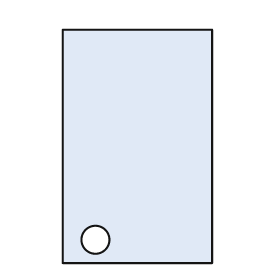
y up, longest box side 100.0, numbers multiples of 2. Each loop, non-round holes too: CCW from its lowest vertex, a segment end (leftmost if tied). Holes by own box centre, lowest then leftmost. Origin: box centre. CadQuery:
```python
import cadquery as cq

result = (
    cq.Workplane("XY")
    .moveTo(-32.0, -50.0)
    .lineTo(32.0, -50.0)
    .lineTo(32.0, 50.0)
    .lineTo(-32.0, 50.0)
    .close()
    .moveTo(-18.0, -40.0)
    .circle(6.0)
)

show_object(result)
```